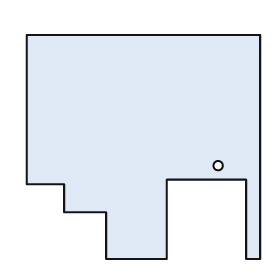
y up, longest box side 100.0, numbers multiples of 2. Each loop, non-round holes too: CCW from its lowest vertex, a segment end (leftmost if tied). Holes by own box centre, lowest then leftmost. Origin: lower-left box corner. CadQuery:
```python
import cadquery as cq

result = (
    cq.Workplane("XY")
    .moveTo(34.0, 0.0)
    .lineTo(60.0, 0.0)
    .lineTo(60.0, 34.0)
    .lineTo(94.0, 34.0)
    .lineTo(94.0, 0.0)
    .lineTo(100.0, 0.0)
    .lineTo(100.0, 96.0)
    .lineTo(0.0, 96.0)
    .lineTo(0.0, 32.0)
    .lineTo(16.0, 32.0)
    .lineTo(16.0, 20.0)
    .lineTo(34.0, 20.0)
    .close()
    .moveTo(82.0, 40.0)
    .circle(2.0)
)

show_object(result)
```